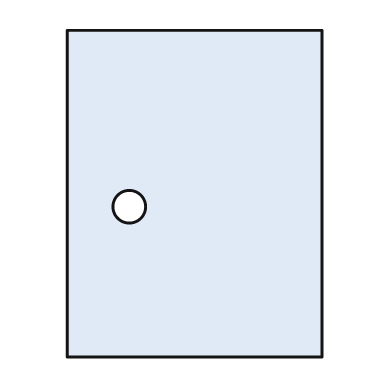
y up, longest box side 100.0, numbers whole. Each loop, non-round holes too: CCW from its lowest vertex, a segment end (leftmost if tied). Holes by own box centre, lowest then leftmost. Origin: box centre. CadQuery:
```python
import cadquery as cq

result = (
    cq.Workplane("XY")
    .moveTo(-39.0, -50.0)
    .lineTo(39.0, -50.0)
    .lineTo(39.0, 50.0)
    .lineTo(-39.0, 50.0)
    .close()
    .moveTo(-20.0, -4.0)
    .circle(5.0)
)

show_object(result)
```